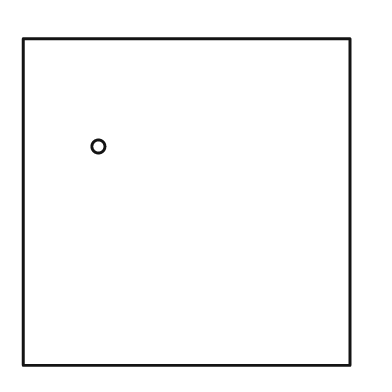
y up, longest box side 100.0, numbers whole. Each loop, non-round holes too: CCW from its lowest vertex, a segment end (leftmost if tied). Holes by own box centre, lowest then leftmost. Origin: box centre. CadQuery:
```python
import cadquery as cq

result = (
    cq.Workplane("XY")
    .moveTo(-50.0, -50.0)
    .lineTo(50.0, -50.0)
    .lineTo(50.0, 50.0)
    .lineTo(-50.0, 50.0)
    .close()
    .moveTo(-27.0, 17.0)
    .circle(2.0)
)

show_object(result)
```